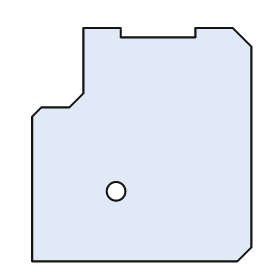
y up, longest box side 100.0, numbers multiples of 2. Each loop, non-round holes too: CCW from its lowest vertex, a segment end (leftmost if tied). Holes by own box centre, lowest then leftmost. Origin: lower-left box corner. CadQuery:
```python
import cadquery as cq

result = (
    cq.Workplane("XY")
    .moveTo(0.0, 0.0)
    .lineTo(88.0, 0.0)
    .lineTo(94.0, 6.0)
    .lineTo(94.0, 92.0)
    .lineTo(86.0, 100.0)
    .lineTo(70.0, 100.0)
    .lineTo(70.0, 96.0)
    .lineTo(38.0, 96.0)
    .lineTo(38.0, 100.0)
    .lineTo(22.0, 100.0)
    .lineTo(22.0, 72.0)
    .lineTo(16.0, 66.0)
    .lineTo(4.0, 66.0)
    .lineTo(0.0, 62.0)
    .close()
    .moveTo(36.0, 30.0)
    .circle(4.0)
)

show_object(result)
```